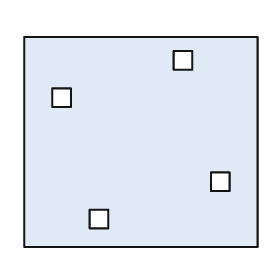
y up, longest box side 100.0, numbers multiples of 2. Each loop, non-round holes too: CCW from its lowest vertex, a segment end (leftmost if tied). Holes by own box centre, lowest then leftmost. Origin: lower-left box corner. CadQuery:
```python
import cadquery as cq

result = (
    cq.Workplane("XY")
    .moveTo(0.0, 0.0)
    .lineTo(100.0, 0.0)
    .lineTo(100.0, 90.0)
    .lineTo(0.0, 90.0)
    .close()
    .moveTo(28.0, 8.0)
    .lineTo(36.0, 8.0)
    .lineTo(36.0, 16.0)
    .lineTo(28.0, 16.0)
    .close()
    .moveTo(80.0, 24.0)
    .lineTo(88.0, 24.0)
    .lineTo(88.0, 32.0)
    .lineTo(80.0, 32.0)
    .close()
    .moveTo(12.0, 60.0)
    .lineTo(20.0, 60.0)
    .lineTo(20.0, 68.0)
    .lineTo(12.0, 68.0)
    .close()
    .moveTo(64.0, 76.0)
    .lineTo(72.0, 76.0)
    .lineTo(72.0, 84.0)
    .lineTo(64.0, 84.0)
    .close()
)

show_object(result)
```